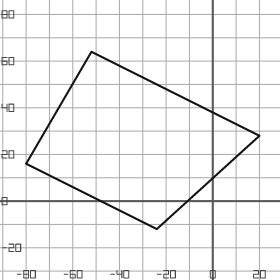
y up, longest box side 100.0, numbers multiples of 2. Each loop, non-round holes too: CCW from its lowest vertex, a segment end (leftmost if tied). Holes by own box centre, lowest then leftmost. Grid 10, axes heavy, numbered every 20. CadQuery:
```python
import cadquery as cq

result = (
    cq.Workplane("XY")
    .moveTo(-24.0, -12.0)
    .lineTo(20.0, 28.0)
    .lineTo(-52.0, 64.0)
    .lineTo(-80.0, 16.0)
    .close()
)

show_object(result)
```